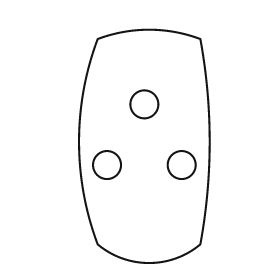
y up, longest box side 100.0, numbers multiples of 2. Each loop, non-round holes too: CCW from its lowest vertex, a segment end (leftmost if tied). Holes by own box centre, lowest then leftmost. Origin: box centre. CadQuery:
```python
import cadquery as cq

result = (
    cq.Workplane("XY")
    .moveTo(-20.0, -42.0)
    .threePointArc((2.0, -50.0), (24.0, -42.0))
    .threePointArc((28.0, 2.0), (24.0, 46.0))
    .threePointArc((2.0, 50.0), (-20.0, 46.0))
    .threePointArc((-28.0, 2.0), (-20.0, -42.0))
    .close()
    .moveTo(-16.0, -8.0)
    .circle(6.0)
    .moveTo(16.0, -8.0)
    .circle(6.0)
    .moveTo(0.0, 18.0)
    .circle(6.0)
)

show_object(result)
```